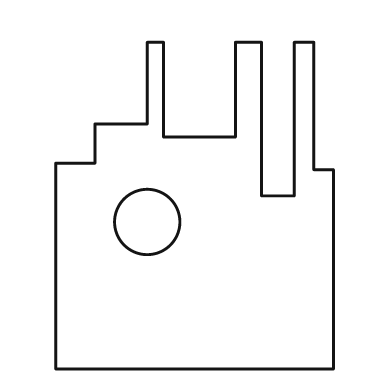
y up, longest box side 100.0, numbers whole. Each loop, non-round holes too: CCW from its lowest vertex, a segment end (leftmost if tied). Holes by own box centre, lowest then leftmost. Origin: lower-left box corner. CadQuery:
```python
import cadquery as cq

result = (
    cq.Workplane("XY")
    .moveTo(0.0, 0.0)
    .lineTo(85.0, 0.0)
    .lineTo(85.0, 61.0)
    .lineTo(79.0, 61.0)
    .lineTo(79.0, 100.0)
    .lineTo(73.0, 100.0)
    .lineTo(73.0, 53.0)
    .lineTo(63.0, 53.0)
    .lineTo(63.0, 100.0)
    .lineTo(55.0, 100.0)
    .lineTo(55.0, 71.0)
    .lineTo(33.0, 71.0)
    .lineTo(33.0, 100.0)
    .lineTo(28.0, 100.0)
    .lineTo(28.0, 75.0)
    .lineTo(12.0, 75.0)
    .lineTo(12.0, 63.0)
    .lineTo(0.0, 63.0)
    .close()
    .moveTo(28.0, 45.0)
    .circle(10.0)
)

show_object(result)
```